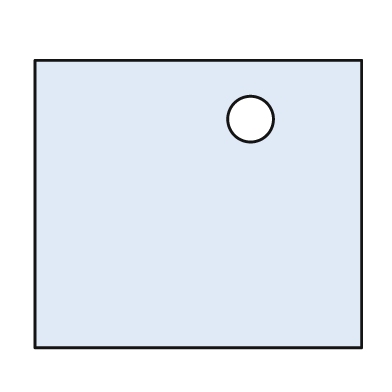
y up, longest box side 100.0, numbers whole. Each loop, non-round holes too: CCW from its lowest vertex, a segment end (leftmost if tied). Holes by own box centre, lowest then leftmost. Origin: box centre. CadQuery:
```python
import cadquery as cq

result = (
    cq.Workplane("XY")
    .moveTo(-50.0, -44.0)
    .lineTo(50.0, -44.0)
    .lineTo(50.0, 44.0)
    .lineTo(-50.0, 44.0)
    .close()
    .moveTo(16.0, 26.0)
    .circle(7.0)
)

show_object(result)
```